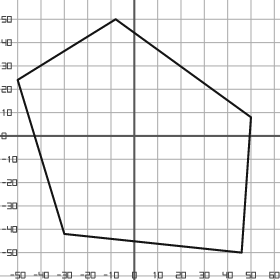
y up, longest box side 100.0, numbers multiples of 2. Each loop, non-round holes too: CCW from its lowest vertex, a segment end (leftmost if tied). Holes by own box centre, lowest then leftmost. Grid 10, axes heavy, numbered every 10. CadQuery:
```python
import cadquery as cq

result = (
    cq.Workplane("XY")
    .moveTo(46.0, -50.0)
    .lineTo(50.0, 8.0)
    .lineTo(-8.0, 50.0)
    .lineTo(-50.0, 24.0)
    .lineTo(-30.0, -42.0)
    .close()
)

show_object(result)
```